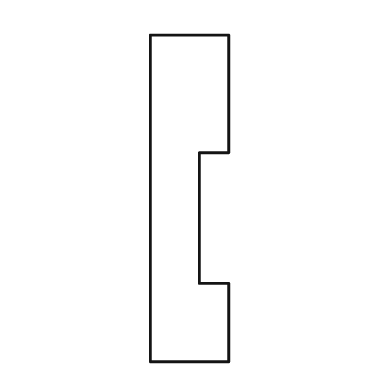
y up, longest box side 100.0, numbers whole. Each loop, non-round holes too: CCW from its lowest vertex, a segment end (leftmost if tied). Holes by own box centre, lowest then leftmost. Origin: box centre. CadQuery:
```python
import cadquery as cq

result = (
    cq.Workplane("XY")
    .moveTo(-12.0, -50.0)
    .lineTo(12.0, -50.0)
    .lineTo(12.0, -26.0)
    .lineTo(3.0, -26.0)
    .lineTo(3.0, 14.0)
    .lineTo(12.0, 14.0)
    .lineTo(12.0, 50.0)
    .lineTo(-12.0, 50.0)
    .close()
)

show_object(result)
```